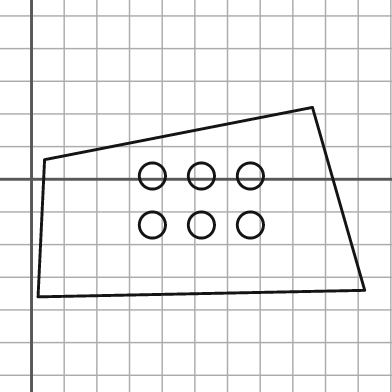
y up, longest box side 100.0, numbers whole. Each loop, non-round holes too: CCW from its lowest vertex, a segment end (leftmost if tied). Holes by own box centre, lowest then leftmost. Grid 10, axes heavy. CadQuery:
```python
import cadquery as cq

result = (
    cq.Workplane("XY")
    .moveTo(2.0, -36.0)
    .lineTo(102.0, -34.0)
    .lineTo(86.0, 22.0)
    .lineTo(4.0, 6.0)
    .close()
    .moveTo(37.0, -14.0)
    .circle(4.0)
    .moveTo(52.0, -14.0)
    .circle(4.0)
    .moveTo(67.0, -14.0)
    .circle(4.0)
    .moveTo(37.0, 1.0)
    .circle(4.0)
    .moveTo(52.0, 1.0)
    .circle(4.0)
    .moveTo(67.0, 1.0)
    .circle(4.0)
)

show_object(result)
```